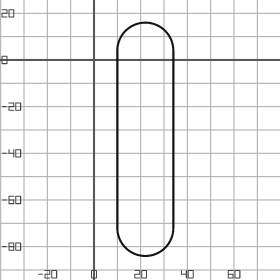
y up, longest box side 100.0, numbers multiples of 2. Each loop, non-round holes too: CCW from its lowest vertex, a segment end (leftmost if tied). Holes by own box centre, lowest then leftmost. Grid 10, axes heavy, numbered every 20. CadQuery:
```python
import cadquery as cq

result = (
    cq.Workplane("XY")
    .moveTo(10.0, -72.0)
    .threePointArc((22.0, -84.0), (34.0, -72.0))
    .lineTo(34.0, 4.0)
    .threePointArc((22.0, 16.0), (10.0, 4.0))
    .close()
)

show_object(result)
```